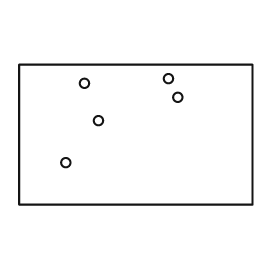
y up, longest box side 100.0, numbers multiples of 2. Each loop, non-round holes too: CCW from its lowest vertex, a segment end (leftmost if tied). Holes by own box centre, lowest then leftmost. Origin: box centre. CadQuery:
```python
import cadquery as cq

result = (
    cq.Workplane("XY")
    .moveTo(-50.0, -30.0)
    .lineTo(50.0, -30.0)
    .lineTo(50.0, 30.0)
    .lineTo(-50.0, 30.0)
    .close()
    .moveTo(-30.0, -12.0)
    .circle(2.0)
    .moveTo(-16.0, 6.0)
    .circle(2.0)
    .moveTo(18.0, 16.0)
    .circle(2.0)
    .moveTo(-22.0, 22.0)
    .circle(2.0)
    .moveTo(14.0, 24.0)
    .circle(2.0)
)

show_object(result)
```